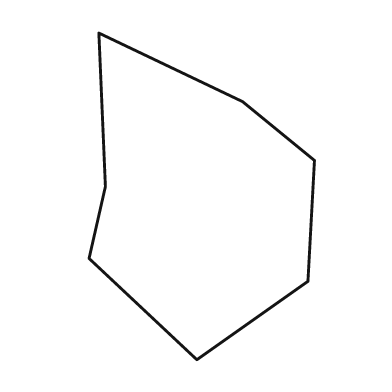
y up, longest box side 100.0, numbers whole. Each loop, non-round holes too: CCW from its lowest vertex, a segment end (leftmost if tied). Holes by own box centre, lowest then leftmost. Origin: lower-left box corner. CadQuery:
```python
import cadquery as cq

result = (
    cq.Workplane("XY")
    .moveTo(33.0, 0.0)
    .lineTo(67.0, 24.0)
    .lineTo(69.0, 61.0)
    .lineTo(47.0, 79.0)
    .lineTo(3.0, 100.0)
    .lineTo(5.0, 53.0)
    .lineTo(0.0, 31.0)
    .close()
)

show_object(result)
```